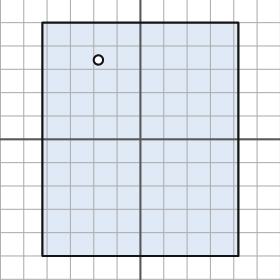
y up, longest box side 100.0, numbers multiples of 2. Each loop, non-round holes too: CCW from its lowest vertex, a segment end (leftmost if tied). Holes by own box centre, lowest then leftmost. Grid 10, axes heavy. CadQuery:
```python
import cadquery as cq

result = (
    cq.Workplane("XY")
    .moveTo(-42.0, -50.0)
    .lineTo(42.0, -50.0)
    .lineTo(42.0, 50.0)
    .lineTo(-42.0, 50.0)
    .close()
    .moveTo(-18.0, 34.0)
    .circle(2.0)
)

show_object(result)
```